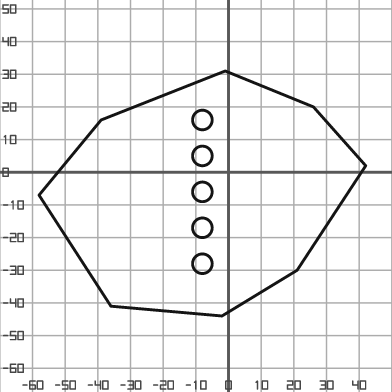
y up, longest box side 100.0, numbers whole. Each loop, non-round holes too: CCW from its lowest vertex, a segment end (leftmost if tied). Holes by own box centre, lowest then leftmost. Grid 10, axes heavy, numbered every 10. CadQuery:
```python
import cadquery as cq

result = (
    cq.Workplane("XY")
    .moveTo(-2.0, -44.0)
    .lineTo(21.0, -30.0)
    .lineTo(42.0, 2.0)
    .lineTo(26.0, 20.0)
    .lineTo(-1.0, 31.0)
    .lineTo(-39.0, 16.0)
    .lineTo(-58.0, -7.0)
    .lineTo(-36.0, -41.0)
    .close()
    .moveTo(-8.0, -28.0)
    .circle(3.0)
    .moveTo(-8.0, -17.0)
    .circle(3.0)
    .moveTo(-8.0, -6.0)
    .circle(3.0)
    .moveTo(-8.0, 5.0)
    .circle(3.0)
    .moveTo(-8.0, 16.0)
    .circle(3.0)
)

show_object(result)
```